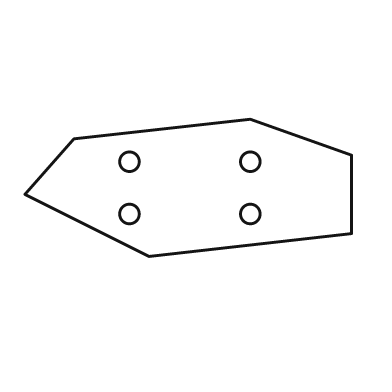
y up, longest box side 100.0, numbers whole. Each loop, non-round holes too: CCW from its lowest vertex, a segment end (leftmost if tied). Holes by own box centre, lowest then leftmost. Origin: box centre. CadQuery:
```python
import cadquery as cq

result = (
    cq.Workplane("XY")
    .moveTo(-12.0, -21.0)
    .lineTo(50.0, -14.0)
    .lineTo(50.0, 10.0)
    .lineTo(19.0, 21.0)
    .lineTo(-35.0, 15.0)
    .lineTo(-50.0, -2.0)
    .close()
    .moveTo(-18.0, -8.0)
    .circle(3.0)
    .moveTo(19.0, -8.0)
    .circle(3.0)
    .moveTo(-18.0, 8.0)
    .circle(3.0)
    .moveTo(19.0, 8.0)
    .circle(3.0)
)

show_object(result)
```